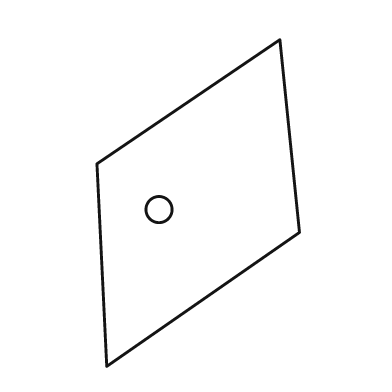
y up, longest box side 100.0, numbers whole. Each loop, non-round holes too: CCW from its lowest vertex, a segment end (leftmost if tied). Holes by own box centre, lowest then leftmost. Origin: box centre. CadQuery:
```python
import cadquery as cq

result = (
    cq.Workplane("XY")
    .moveTo(-28.0, -50.0)
    .lineTo(31.0, -9.0)
    .lineTo(25.0, 50.0)
    .lineTo(-31.0, 12.0)
    .close()
    .moveTo(-12.0, -2.0)
    .circle(4.0)
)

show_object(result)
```